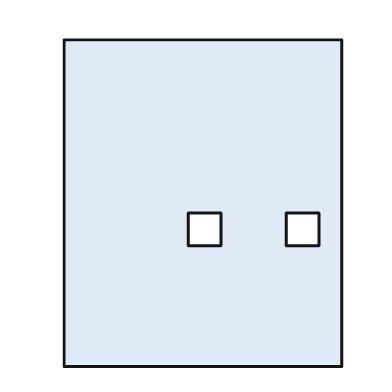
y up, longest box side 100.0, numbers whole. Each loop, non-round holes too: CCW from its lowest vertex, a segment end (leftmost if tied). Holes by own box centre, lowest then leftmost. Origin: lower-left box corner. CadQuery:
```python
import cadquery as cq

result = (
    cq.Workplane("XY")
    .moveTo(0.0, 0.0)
    .lineTo(85.0, 0.0)
    .lineTo(85.0, 100.0)
    .lineTo(0.0, 100.0)
    .close()
    .moveTo(38.0, 37.0)
    .lineTo(48.0, 37.0)
    .lineTo(48.0, 47.0)
    .lineTo(38.0, 47.0)
    .close()
    .moveTo(68.0, 37.0)
    .lineTo(78.0, 37.0)
    .lineTo(78.0, 47.0)
    .lineTo(68.0, 47.0)
    .close()
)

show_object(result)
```